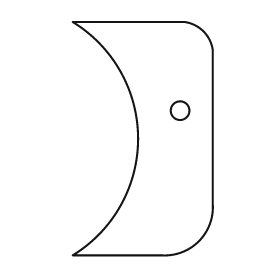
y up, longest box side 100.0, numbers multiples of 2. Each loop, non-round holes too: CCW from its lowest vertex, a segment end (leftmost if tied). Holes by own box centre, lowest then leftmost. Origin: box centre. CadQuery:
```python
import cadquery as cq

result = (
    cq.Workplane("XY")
    .moveTo(-30.0, -50.0)
    .lineTo(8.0, -50.0)
    .threePointArc((24.0, -44.0), (30.0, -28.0))
    .lineTo(30.0, 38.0)
    .threePointArc((26.0, 46.0), (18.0, 50.0))
    .lineTo(-30.0, 50.0)
    .threePointArc((-2.0, 0.0), (-30.0, -50.0))
    .close()
    .moveTo(16.0, 12.0)
    .circle(4.0)
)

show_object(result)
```